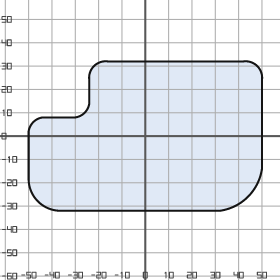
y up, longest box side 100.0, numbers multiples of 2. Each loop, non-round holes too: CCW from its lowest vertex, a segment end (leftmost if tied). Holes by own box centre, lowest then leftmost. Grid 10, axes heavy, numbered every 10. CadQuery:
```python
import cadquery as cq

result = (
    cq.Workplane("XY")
    .moveTo(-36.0, -32.0)
    .lineTo(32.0, -32.0)
    .threePointArc((44.0, -26.0), (50.0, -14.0))
    .lineTo(50.0, 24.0)
    .threePointArc((48.0, 30.0), (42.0, 32.0))
    .lineTo(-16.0, 32.0)
    .threePointArc((-22.0, 30.0), (-24.0, 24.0))
    .lineTo(-24.0, 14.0)
    .threePointArc((-26.0, 10.0), (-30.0, 8.0))
    .lineTo(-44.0, 8.0)
    .threePointArc((-48.0, 6.0), (-50.0, 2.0))
    .lineTo(-50.0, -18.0)
    .threePointArc((-46.0, -28.0), (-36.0, -32.0))
    .close()
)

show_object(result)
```